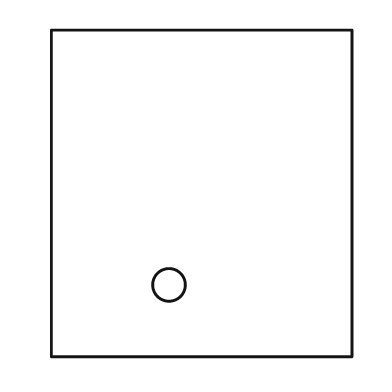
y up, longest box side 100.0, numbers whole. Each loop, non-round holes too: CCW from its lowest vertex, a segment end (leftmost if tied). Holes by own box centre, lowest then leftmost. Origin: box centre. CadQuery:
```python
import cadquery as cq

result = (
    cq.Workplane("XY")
    .moveTo(-46.0, -50.0)
    .lineTo(46.0, -50.0)
    .lineTo(46.0, 50.0)
    .lineTo(-46.0, 50.0)
    .close()
    .moveTo(-10.0, -28.0)
    .circle(5.0)
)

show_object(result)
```